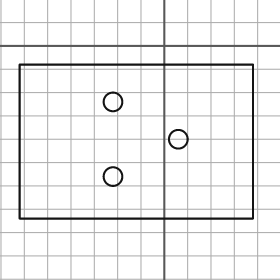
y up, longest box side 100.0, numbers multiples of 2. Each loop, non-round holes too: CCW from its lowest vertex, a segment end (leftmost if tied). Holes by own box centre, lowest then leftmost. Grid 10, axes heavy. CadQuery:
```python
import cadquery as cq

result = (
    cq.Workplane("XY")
    .moveTo(-62.0, -74.0)
    .lineTo(38.0, -74.0)
    .lineTo(38.0, -8.0)
    .lineTo(-62.0, -8.0)
    .close()
    .moveTo(-22.0, -56.0)
    .circle(4.0)
    .moveTo(6.0, -40.0)
    .circle(4.0)
    .moveTo(-22.0, -24.0)
    .circle(4.0)
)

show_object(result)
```